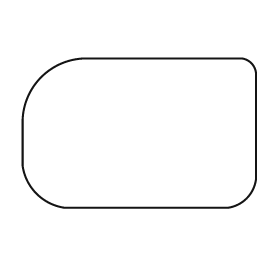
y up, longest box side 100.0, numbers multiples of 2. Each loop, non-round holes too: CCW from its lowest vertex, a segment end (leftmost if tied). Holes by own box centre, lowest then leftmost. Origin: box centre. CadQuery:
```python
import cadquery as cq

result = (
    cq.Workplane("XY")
    .moveTo(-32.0, -32.0)
    .lineTo(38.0, -32.0)
    .threePointArc((46.0, -28.0), (50.0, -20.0))
    .lineTo(50.0, 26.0)
    .threePointArc((48.0, 30.0), (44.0, 32.0))
    .lineTo(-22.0, 32.0)
    .threePointArc((-42.0, 24.0), (-50.0, 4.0))
    .lineTo(-50.0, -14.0)
    .threePointArc((-44.0, -26.0), (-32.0, -32.0))
    .close()
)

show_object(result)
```